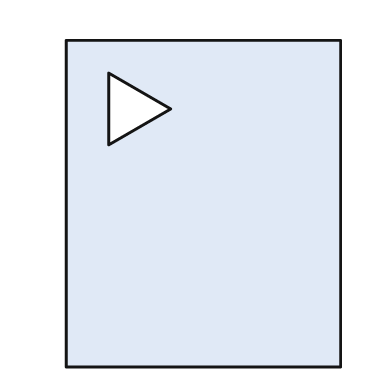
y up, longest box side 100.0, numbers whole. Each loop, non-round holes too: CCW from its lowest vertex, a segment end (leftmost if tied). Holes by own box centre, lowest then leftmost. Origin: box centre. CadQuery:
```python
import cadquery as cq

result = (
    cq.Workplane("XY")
    .moveTo(-42.0, -50.0)
    .lineTo(42.0, -50.0)
    .lineTo(42.0, 50.0)
    .lineTo(-42.0, 50.0)
    .close()
    .moveTo(-29.0, 18.0)
    .lineTo(-10.0, 29.0)
    .lineTo(-29.0, 40.0)
    .close()
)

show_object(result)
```